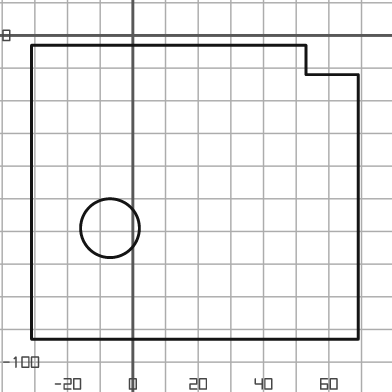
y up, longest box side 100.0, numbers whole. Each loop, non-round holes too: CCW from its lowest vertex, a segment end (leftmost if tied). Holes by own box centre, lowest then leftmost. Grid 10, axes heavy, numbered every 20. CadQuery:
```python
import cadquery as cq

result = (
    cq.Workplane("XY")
    .moveTo(-31.0, -93.0)
    .lineTo(69.0, -93.0)
    .lineTo(69.0, -12.0)
    .lineTo(53.0, -12.0)
    .lineTo(53.0, -3.0)
    .lineTo(-31.0, -3.0)
    .close()
    .moveTo(-7.0, -59.0)
    .circle(9.0)
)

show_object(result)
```